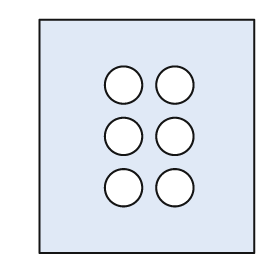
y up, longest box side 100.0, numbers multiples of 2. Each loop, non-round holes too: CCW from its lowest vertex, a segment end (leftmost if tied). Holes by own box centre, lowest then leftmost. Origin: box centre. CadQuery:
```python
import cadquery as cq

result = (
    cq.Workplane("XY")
    .moveTo(-46.0, -50.0)
    .lineTo(46.0, -50.0)
    .lineTo(46.0, 50.0)
    .lineTo(-46.0, 50.0)
    .close()
    .moveTo(-10.0, -22.0)
    .circle(8.0)
    .moveTo(12.0, -22.0)
    .circle(8.0)
    .moveTo(-10.0, 0.0)
    .circle(8.0)
    .moveTo(12.0, 0.0)
    .circle(8.0)
    .moveTo(-10.0, 22.0)
    .circle(8.0)
    .moveTo(12.0, 22.0)
    .circle(8.0)
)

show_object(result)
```